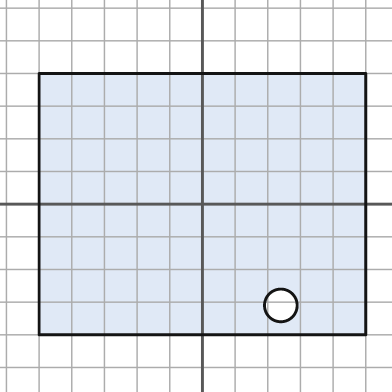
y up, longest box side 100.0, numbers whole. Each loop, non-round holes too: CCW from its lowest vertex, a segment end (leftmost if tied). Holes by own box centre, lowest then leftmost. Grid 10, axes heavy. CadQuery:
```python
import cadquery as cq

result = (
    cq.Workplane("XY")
    .moveTo(-50.0, -40.0)
    .lineTo(50.0, -40.0)
    .lineTo(50.0, 40.0)
    .lineTo(-50.0, 40.0)
    .close()
    .moveTo(24.0, -31.0)
    .circle(5.0)
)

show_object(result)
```